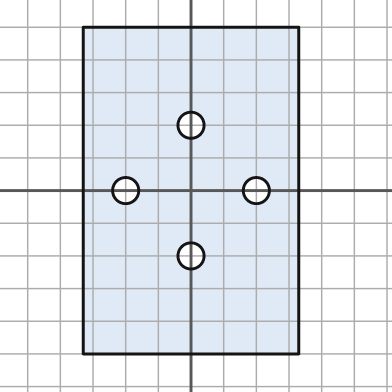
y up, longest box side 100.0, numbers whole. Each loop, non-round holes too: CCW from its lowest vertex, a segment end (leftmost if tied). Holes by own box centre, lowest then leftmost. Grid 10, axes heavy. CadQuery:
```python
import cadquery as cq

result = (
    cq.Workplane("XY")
    .moveTo(-33.0, -50.0)
    .lineTo(33.0, -50.0)
    .lineTo(33.0, 50.0)
    .lineTo(-33.0, 50.0)
    .close()
    .moveTo(0.0, -20.0)
    .circle(4.0)
    .moveTo(-20.0, 0.0)
    .circle(4.0)
    .moveTo(20.0, 0.0)
    .circle(4.0)
    .moveTo(0.0, 20.0)
    .circle(4.0)
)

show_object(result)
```